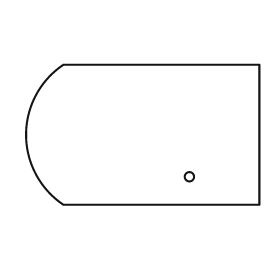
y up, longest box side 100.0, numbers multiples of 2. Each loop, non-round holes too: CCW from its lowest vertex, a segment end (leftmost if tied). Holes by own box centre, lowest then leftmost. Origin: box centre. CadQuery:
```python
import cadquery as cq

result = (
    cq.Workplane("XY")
    .moveTo(-34.0, -30.0)
    .lineTo(50.0, -30.0)
    .lineTo(50.0, 30.0)
    .lineTo(-34.0, 30.0)
    .threePointArc((-50.0, 0.0), (-34.0, -30.0))
    .close()
    .moveTo(20.0, -18.0)
    .circle(2.0)
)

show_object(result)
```